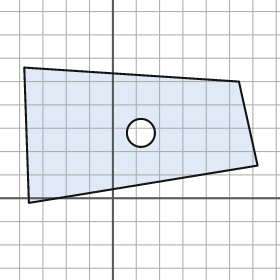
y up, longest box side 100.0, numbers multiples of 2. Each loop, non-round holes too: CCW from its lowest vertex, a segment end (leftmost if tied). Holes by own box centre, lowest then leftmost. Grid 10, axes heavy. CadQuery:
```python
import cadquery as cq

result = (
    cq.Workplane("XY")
    .moveTo(-36.0, -2.0)
    .lineTo(62.0, 14.0)
    .lineTo(54.0, 50.0)
    .lineTo(-38.0, 56.0)
    .close()
    .moveTo(12.0, 28.0)
    .circle(6.0)
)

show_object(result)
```